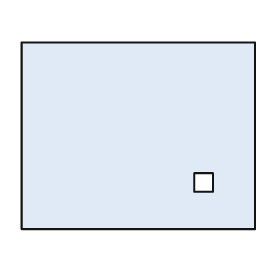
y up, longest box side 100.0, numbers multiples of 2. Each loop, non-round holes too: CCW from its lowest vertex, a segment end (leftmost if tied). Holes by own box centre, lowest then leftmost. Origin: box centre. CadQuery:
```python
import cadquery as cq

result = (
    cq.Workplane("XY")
    .moveTo(-50.0, -40.0)
    .lineTo(50.0, -40.0)
    .lineTo(50.0, 40.0)
    .lineTo(-50.0, 40.0)
    .close()
    .moveTo(24.0, -24.0)
    .lineTo(32.0, -24.0)
    .lineTo(32.0, -16.0)
    .lineTo(24.0, -16.0)
    .close()
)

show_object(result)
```